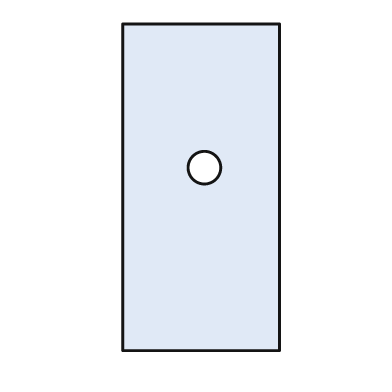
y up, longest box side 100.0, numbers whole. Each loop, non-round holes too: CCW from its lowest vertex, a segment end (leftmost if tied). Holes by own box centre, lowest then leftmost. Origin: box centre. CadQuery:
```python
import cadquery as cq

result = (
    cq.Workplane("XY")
    .moveTo(-24.0, -50.0)
    .lineTo(24.0, -50.0)
    .lineTo(24.0, 50.0)
    .lineTo(-24.0, 50.0)
    .close()
    .moveTo(1.0, 6.0)
    .circle(5.0)
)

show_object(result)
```